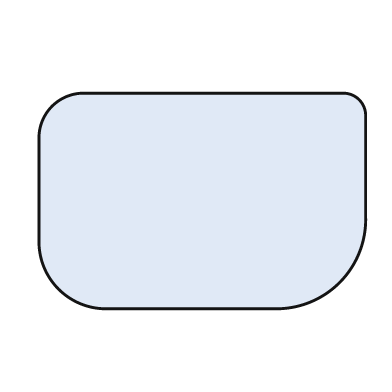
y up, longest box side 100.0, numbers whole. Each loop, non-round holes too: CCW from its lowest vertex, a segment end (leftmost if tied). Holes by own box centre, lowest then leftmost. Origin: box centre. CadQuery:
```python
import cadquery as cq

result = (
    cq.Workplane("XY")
    .moveTo(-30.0, -33.0)
    .lineTo(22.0, -33.0)
    .threePointArc((42.0, -25.0), (50.0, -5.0))
    .lineTo(50.0, 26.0)
    .threePointArc((48.0, 31.0), (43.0, 33.0))
    .lineTo(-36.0, 33.0)
    .threePointArc((-46.0, 29.0), (-50.0, 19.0))
    .lineTo(-50.0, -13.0)
    .threePointArc((-44.0, -27.0), (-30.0, -33.0))
    .close()
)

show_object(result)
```